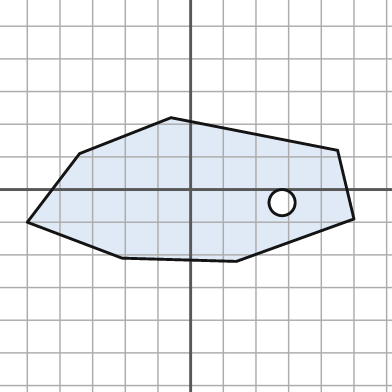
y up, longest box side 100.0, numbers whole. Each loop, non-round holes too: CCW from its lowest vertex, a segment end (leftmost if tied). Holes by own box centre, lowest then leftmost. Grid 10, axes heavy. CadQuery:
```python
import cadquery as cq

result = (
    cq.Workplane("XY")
    .moveTo(14.0, -22.0)
    .lineTo(50.0, -9.0)
    .lineTo(45.0, 12.0)
    .lineTo(-6.0, 22.0)
    .lineTo(-34.0, 11.0)
    .lineTo(-50.0, -10.0)
    .lineTo(-21.0, -21.0)
    .close()
    .moveTo(28.0, -4.0)
    .circle(4.0)
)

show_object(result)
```